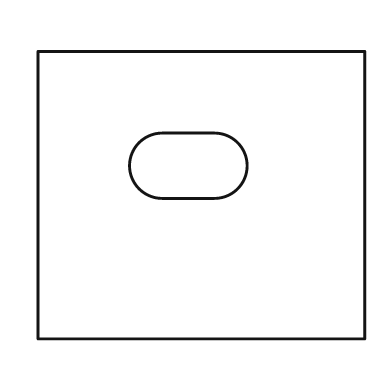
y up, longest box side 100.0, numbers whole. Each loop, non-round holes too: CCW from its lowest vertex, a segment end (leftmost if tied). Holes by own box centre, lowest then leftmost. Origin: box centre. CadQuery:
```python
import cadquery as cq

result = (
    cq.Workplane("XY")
    .moveTo(-50.0, -44.0)
    .lineTo(50.0, -44.0)
    .lineTo(50.0, 44.0)
    .lineTo(-50.0, 44.0)
    .close()
    .moveTo(-12.0, -1.0)
    .lineTo(4.0, -1.0)
    .threePointArc((14.0, 9.0), (4.0, 19.0))
    .lineTo(-12.0, 19.0)
    .threePointArc((-22.0, 9.0), (-12.0, -1.0))
    .close()
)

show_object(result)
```